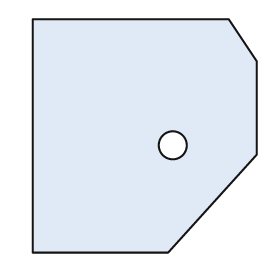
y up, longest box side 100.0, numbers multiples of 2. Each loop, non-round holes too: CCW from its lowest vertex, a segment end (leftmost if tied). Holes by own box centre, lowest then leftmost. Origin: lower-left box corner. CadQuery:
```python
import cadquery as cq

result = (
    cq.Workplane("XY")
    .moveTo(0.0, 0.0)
    .lineTo(58.0, 0.0)
    .lineTo(96.0, 42.0)
    .lineTo(96.0, 82.0)
    .lineTo(84.0, 100.0)
    .lineTo(0.0, 100.0)
    .close()
    .moveTo(60.0, 46.0)
    .circle(6.0)
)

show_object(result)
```